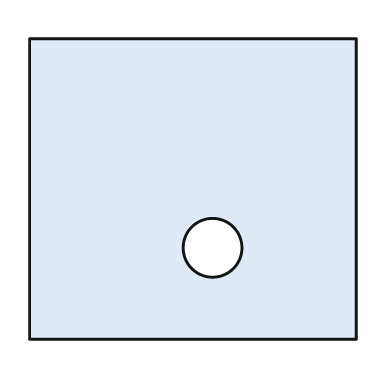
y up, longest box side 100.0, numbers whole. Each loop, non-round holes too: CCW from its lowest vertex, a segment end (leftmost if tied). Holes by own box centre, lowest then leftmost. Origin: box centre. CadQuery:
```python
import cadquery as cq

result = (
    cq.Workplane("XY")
    .moveTo(-50.0, -46.0)
    .lineTo(50.0, -46.0)
    .lineTo(50.0, 46.0)
    .lineTo(-50.0, 46.0)
    .close()
    .moveTo(6.0, -18.0)
    .circle(9.0)
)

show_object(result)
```